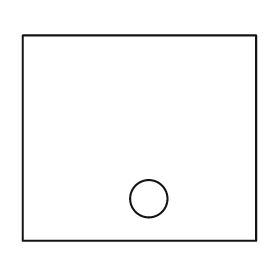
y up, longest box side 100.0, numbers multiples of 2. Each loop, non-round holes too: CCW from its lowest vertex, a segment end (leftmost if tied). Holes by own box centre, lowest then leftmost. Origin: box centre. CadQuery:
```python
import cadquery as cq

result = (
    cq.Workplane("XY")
    .moveTo(-50.0, -44.0)
    .lineTo(50.0, -44.0)
    .lineTo(50.0, 44.0)
    .lineTo(-50.0, 44.0)
    .close()
    .moveTo(4.0, -26.0)
    .circle(8.0)
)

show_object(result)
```